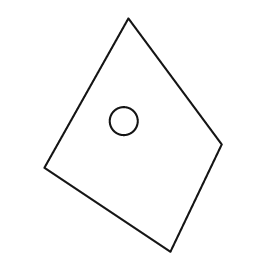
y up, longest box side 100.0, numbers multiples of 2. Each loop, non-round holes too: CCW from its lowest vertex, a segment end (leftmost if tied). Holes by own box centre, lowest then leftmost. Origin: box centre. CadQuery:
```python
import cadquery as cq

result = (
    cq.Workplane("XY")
    .moveTo(16.0, -50.0)
    .lineTo(38.0, -4.0)
    .lineTo(-2.0, 50.0)
    .lineTo(-38.0, -14.0)
    .close()
    .moveTo(-4.0, 6.0)
    .circle(6.0)
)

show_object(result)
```